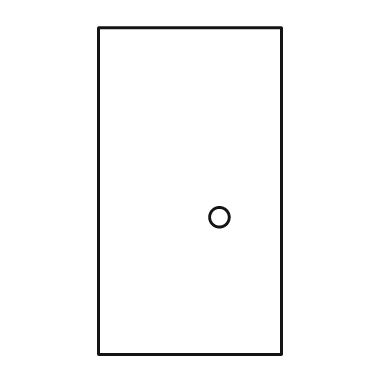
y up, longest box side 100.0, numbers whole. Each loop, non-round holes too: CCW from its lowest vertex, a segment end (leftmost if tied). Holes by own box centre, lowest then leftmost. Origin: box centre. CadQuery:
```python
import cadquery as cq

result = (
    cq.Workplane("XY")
    .moveTo(-28.0, -50.0)
    .lineTo(28.0, -50.0)
    .lineTo(28.0, 50.0)
    .lineTo(-28.0, 50.0)
    .close()
    .moveTo(9.0, -8.0)
    .circle(3.0)
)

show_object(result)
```